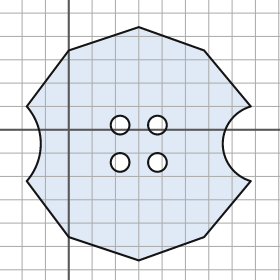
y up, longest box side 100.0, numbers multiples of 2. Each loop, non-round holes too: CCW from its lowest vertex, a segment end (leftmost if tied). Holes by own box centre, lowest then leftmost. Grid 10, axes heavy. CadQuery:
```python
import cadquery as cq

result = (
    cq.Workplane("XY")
    .moveTo(30.0, -56.0)
    .lineTo(58.0, -46.0)
    .lineTo(78.0, -22.0)
    .threePointArc((66.0, -6.0), (78.0, 10.0))
    .lineTo(58.0, 34.0)
    .lineTo(30.0, 44.0)
    .lineTo(0.0, 34.0)
    .lineTo(-18.0, 10.0)
    .threePointArc((-12.0, -6.0), (-18.0, -22.0))
    .lineTo(0.0, -46.0)
    .close()
    .moveTo(22.0, -14.0)
    .circle(4.0)
    .moveTo(38.0, -14.0)
    .circle(4.0)
    .moveTo(22.0, 2.0)
    .circle(4.0)
    .moveTo(38.0, 2.0)
    .circle(4.0)
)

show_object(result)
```